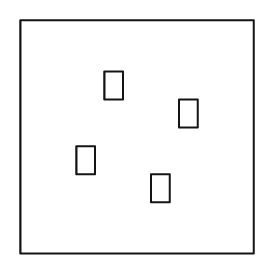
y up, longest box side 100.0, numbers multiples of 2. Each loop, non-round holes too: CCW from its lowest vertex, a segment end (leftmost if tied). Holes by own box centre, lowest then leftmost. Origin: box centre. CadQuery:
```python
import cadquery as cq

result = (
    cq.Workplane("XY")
    .moveTo(-50.0, -50.0)
    .lineTo(50.0, -50.0)
    .lineTo(50.0, 50.0)
    .lineTo(-50.0, 50.0)
    .close()
    .moveTo(6.0, -28.0)
    .lineTo(14.0, -28.0)
    .lineTo(14.0, -16.0)
    .lineTo(6.0, -16.0)
    .close()
    .moveTo(-26.0, -16.0)
    .lineTo(-18.0, -16.0)
    .lineTo(-18.0, -4.0)
    .lineTo(-26.0, -4.0)
    .close()
    .moveTo(18.0, 4.0)
    .lineTo(26.0, 4.0)
    .lineTo(26.0, 16.0)
    .lineTo(18.0, 16.0)
    .close()
    .moveTo(-14.0, 16.0)
    .lineTo(-6.0, 16.0)
    .lineTo(-6.0, 28.0)
    .lineTo(-14.0, 28.0)
    .close()
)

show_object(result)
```